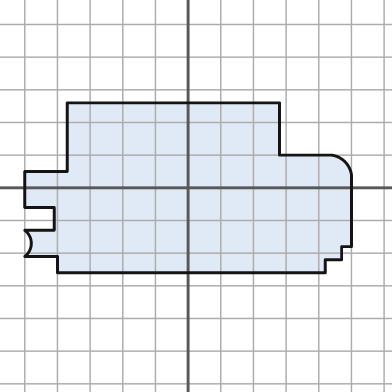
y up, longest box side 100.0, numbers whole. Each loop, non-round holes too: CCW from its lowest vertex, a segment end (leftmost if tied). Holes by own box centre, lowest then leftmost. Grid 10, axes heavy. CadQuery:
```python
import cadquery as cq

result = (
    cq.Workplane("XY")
    .moveTo(-40.0, -26.0)
    .lineTo(42.0, -26.0)
    .lineTo(42.0, -22.0)
    .lineTo(47.0, -22.0)
    .lineTo(47.0, -18.0)
    .lineTo(50.0, -18.0)
    .lineTo(50.0, 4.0)
    .threePointArc((48.0, 8.0), (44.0, 10.0))
    .lineTo(28.0, 10.0)
    .lineTo(28.0, 26.0)
    .lineTo(-37.0, 26.0)
    .lineTo(-37.0, 5.0)
    .lineTo(-50.0, 5.0)
    .lineTo(-50.0, -6.0)
    .lineTo(-41.0, -6.0)
    .lineTo(-41.0, -13.0)
    .lineTo(-50.0, -13.0)
    .threePointArc((-48.0, -17.0), (-50.0, -21.0))
    .lineTo(-40.0, -21.0)
    .close()
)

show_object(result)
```